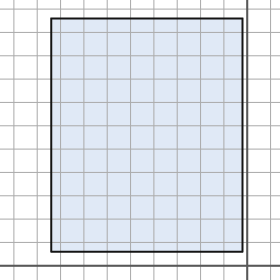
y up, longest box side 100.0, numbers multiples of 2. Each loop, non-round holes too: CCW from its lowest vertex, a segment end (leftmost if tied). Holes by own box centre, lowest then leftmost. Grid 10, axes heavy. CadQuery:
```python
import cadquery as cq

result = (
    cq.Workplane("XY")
    .moveTo(-84.0, 6.0)
    .lineTo(-2.0, 6.0)
    .lineTo(-2.0, 106.0)
    .lineTo(-84.0, 106.0)
    .close()
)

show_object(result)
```